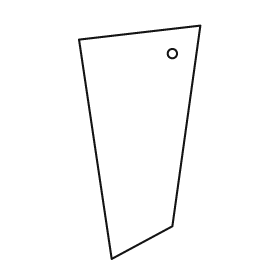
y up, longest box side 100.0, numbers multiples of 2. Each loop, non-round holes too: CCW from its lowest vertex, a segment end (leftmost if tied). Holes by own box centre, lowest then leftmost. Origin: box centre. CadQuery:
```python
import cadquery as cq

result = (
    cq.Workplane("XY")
    .moveTo(-12.0, -50.0)
    .lineTo(14.0, -36.0)
    .lineTo(26.0, 50.0)
    .lineTo(-26.0, 44.0)
    .close()
    .moveTo(14.0, 38.0)
    .circle(2.0)
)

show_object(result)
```